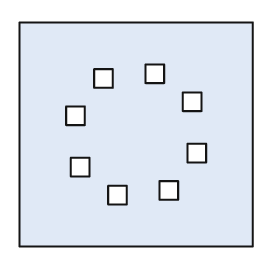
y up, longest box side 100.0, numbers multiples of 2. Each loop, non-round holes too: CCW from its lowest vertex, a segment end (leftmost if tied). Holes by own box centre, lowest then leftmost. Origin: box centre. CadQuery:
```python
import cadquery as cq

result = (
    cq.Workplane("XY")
    .moveTo(-50.0, -48.0)
    .lineTo(50.0, -48.0)
    .lineTo(50.0, 48.0)
    .lineTo(-50.0, 48.0)
    .close()
    .moveTo(-12.0, -30.0)
    .lineTo(-4.0, -30.0)
    .lineTo(-4.0, -22.0)
    .lineTo(-12.0, -22.0)
    .close()
    .moveTo(10.0, -28.0)
    .lineTo(18.0, -28.0)
    .lineTo(18.0, -20.0)
    .lineTo(10.0, -20.0)
    .close()
    .moveTo(-28.0, -18.0)
    .lineTo(-20.0, -18.0)
    .lineTo(-20.0, -10.0)
    .lineTo(-28.0, -10.0)
    .close()
    .moveTo(22.0, -12.0)
    .lineTo(30.0, -12.0)
    .lineTo(30.0, -4.0)
    .lineTo(22.0, -4.0)
    .close()
    .moveTo(-30.0, 4.0)
    .lineTo(-22.0, 4.0)
    .lineTo(-22.0, 12.0)
    .lineTo(-30.0, 12.0)
    .close()
    .moveTo(20.0, 10.0)
    .lineTo(28.0, 10.0)
    .lineTo(28.0, 18.0)
    .lineTo(20.0, 18.0)
    .close()
    .moveTo(-18.0, 20.0)
    .lineTo(-10.0, 20.0)
    .lineTo(-10.0, 28.0)
    .lineTo(-18.0, 28.0)
    .close()
    .moveTo(4.0, 22.0)
    .lineTo(12.0, 22.0)
    .lineTo(12.0, 30.0)
    .lineTo(4.0, 30.0)
    .close()
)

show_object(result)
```